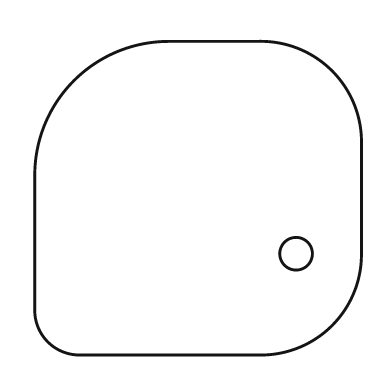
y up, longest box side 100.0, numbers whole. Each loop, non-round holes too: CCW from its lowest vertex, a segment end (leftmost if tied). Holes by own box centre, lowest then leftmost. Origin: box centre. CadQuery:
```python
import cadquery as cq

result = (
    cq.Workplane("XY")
    .moveTo(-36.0, -48.0)
    .lineTo(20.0, -48.0)
    .threePointArc((41.0, -39.0), (50.0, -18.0))
    .lineTo(50.0, 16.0)
    .threePointArc((41.0, 39.0), (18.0, 48.0))
    .lineTo(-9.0, 48.0)
    .threePointArc((-38.0, 36.0), (-50.0, 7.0))
    .lineTo(-50.0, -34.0)
    .threePointArc((-46.0, -44.0), (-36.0, -48.0))
    .close()
    .moveTo(30.0, -17.0)
    .circle(5.0)
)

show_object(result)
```